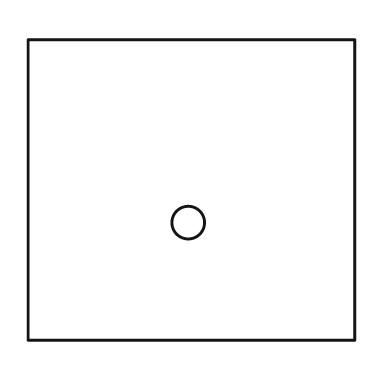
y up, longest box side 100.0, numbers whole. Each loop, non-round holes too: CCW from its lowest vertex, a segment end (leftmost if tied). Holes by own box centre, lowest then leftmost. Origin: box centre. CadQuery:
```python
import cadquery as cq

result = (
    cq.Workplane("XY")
    .moveTo(-50.0, -46.0)
    .lineTo(50.0, -46.0)
    .lineTo(50.0, 46.0)
    .lineTo(-50.0, 46.0)
    .close()
    .moveTo(-1.0, -10.0)
    .circle(5.0)
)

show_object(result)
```